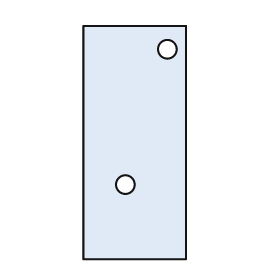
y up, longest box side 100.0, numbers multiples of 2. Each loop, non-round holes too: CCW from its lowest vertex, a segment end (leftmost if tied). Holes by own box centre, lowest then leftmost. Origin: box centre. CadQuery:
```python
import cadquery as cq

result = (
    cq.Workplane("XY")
    .moveTo(-22.0, -50.0)
    .lineTo(22.0, -50.0)
    .lineTo(22.0, 50.0)
    .lineTo(-22.0, 50.0)
    .close()
    .moveTo(-4.0, -18.0)
    .circle(4.0)
    .moveTo(14.0, 40.0)
    .circle(4.0)
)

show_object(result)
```